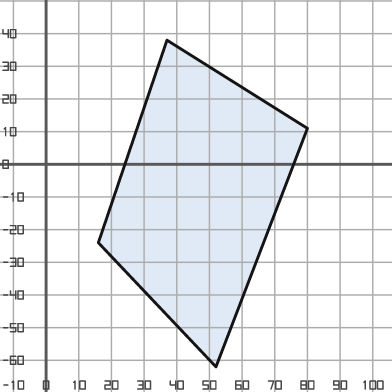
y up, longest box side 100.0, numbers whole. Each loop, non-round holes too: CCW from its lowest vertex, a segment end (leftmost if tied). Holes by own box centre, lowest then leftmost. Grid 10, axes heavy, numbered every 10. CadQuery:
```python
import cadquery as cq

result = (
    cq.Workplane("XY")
    .moveTo(52.0, -62.0)
    .lineTo(80.0, 11.0)
    .lineTo(37.0, 38.0)
    .lineTo(16.0, -24.0)
    .close()
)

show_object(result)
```